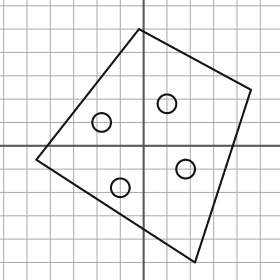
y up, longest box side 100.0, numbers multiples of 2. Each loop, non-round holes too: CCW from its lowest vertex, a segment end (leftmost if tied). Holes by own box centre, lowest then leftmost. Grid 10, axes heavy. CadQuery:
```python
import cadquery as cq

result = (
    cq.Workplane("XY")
    .moveTo(22.0, -50.0)
    .lineTo(46.0, 24.0)
    .lineTo(-2.0, 50.0)
    .lineTo(-46.0, -6.0)
    .close()
    .moveTo(-10.0, -18.0)
    .circle(4.0)
    .moveTo(18.0, -10.0)
    .circle(4.0)
    .moveTo(-18.0, 10.0)
    .circle(4.0)
    .moveTo(10.0, 18.0)
    .circle(4.0)
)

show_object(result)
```